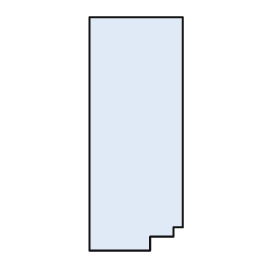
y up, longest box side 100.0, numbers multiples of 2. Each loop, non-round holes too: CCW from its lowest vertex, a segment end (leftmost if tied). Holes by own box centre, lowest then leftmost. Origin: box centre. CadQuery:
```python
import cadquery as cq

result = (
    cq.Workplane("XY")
    .moveTo(-20.0, -50.0)
    .lineTo(6.0, -50.0)
    .lineTo(6.0, -44.0)
    .lineTo(16.0, -44.0)
    .lineTo(16.0, -40.0)
    .lineTo(20.0, -40.0)
    .lineTo(20.0, 50.0)
    .lineTo(-20.0, 50.0)
    .close()
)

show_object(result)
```